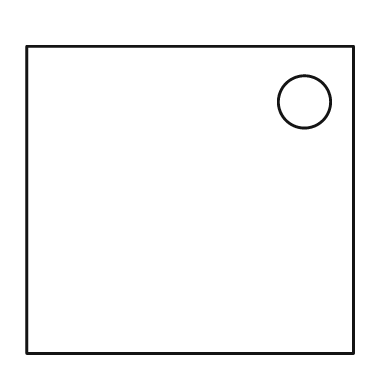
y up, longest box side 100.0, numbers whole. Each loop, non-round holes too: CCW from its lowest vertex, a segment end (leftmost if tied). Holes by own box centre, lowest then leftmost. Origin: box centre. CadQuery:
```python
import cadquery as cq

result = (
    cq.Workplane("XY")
    .moveTo(-50.0, -47.0)
    .lineTo(50.0, -47.0)
    .lineTo(50.0, 47.0)
    .lineTo(-50.0, 47.0)
    .close()
    .moveTo(35.0, 30.0)
    .circle(8.0)
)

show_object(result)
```